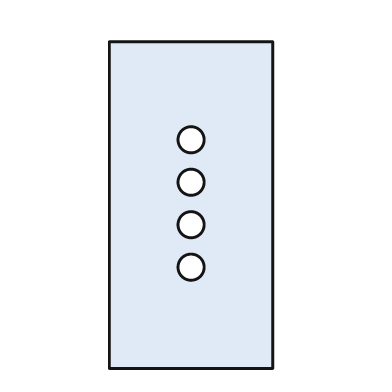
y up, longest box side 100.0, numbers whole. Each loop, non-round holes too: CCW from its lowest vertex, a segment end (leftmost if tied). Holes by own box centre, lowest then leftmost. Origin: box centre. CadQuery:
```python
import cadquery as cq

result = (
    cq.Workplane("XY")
    .moveTo(-25.0, -50.0)
    .lineTo(25.0, -50.0)
    .lineTo(25.0, 50.0)
    .lineTo(-25.0, 50.0)
    .close()
    .moveTo(0.0, -19.0)
    .circle(4.0)
    .moveTo(0.0, -6.0)
    .circle(4.0)
    .moveTo(0.0, 7.0)
    .circle(4.0)
    .moveTo(0.0, 20.0)
    .circle(4.0)
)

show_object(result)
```